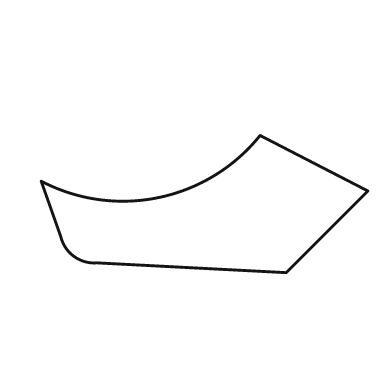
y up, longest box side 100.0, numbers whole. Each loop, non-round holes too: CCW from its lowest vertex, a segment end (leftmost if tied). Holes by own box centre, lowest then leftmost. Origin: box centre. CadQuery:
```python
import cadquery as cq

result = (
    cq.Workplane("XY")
    .moveTo(25.0, -21.0)
    .lineTo(50.0, 4.0)
    .lineTo(17.0, 21.0)
    .threePointArc((-14.0, 2.0), (-50.0, 7.0))
    .lineTo(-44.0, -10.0)
    .threePointArc((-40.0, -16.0), (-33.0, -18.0))
    .close()
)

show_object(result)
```